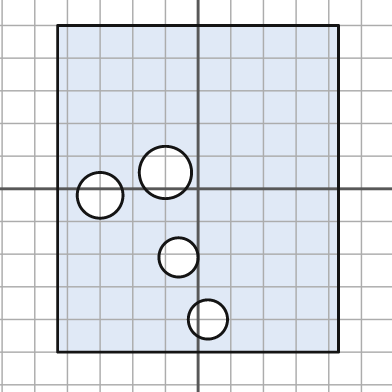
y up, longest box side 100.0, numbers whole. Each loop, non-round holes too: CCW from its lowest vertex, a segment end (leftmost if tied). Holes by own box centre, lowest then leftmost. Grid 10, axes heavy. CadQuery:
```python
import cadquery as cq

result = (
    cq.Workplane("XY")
    .moveTo(-43.0, -50.0)
    .lineTo(43.0, -50.0)
    .lineTo(43.0, 50.0)
    .lineTo(-43.0, 50.0)
    .close()
    .moveTo(3.0, -40.0)
    .circle(6.0)
    .moveTo(-6.0, -21.0)
    .circle(6.0)
    .moveTo(-30.0, -2.0)
    .circle(7.0)
    .moveTo(-10.0, 5.0)
    .circle(8.0)
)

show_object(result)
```